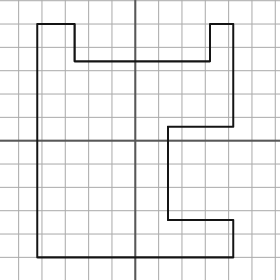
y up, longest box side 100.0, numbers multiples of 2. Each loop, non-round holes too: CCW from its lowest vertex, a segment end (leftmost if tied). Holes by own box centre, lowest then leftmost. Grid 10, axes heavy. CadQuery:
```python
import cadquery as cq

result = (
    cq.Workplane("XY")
    .moveTo(-42.0, -50.0)
    .lineTo(42.0, -50.0)
    .lineTo(42.0, -34.0)
    .lineTo(14.0, -34.0)
    .lineTo(14.0, 6.0)
    .lineTo(42.0, 6.0)
    .lineTo(42.0, 50.0)
    .lineTo(32.0, 50.0)
    .lineTo(32.0, 34.0)
    .lineTo(-26.0, 34.0)
    .lineTo(-26.0, 50.0)
    .lineTo(-42.0, 50.0)
    .close()
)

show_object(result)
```